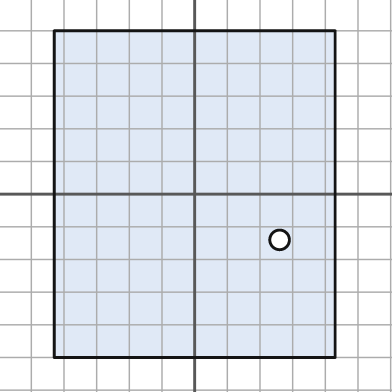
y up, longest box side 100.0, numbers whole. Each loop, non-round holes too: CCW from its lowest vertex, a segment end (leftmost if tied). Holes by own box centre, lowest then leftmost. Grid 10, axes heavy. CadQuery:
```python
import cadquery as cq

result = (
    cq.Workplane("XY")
    .moveTo(-43.0, -50.0)
    .lineTo(43.0, -50.0)
    .lineTo(43.0, 50.0)
    .lineTo(-43.0, 50.0)
    .close()
    .moveTo(26.0, -14.0)
    .circle(3.0)
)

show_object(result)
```